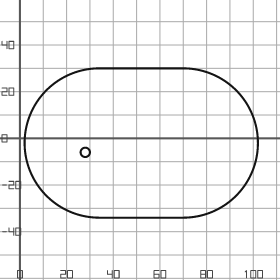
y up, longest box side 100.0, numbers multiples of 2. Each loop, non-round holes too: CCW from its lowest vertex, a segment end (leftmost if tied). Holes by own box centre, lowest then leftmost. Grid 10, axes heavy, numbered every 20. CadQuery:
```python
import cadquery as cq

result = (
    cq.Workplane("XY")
    .moveTo(34.0, -34.0)
    .lineTo(70.0, -34.0)
    .threePointArc((102.0, -2.0), (70.0, 30.0))
    .lineTo(34.0, 30.0)
    .threePointArc((2.0, -2.0), (34.0, -34.0))
    .close()
    .moveTo(28.0, -6.0)
    .circle(2.0)
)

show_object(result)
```